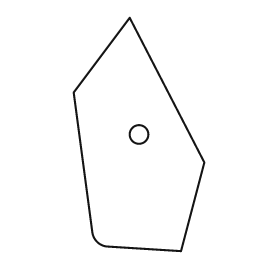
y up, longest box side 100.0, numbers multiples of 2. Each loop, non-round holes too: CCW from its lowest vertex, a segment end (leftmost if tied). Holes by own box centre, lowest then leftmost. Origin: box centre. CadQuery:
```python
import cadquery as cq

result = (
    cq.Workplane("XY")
    .moveTo(18.0, -50.0)
    .lineTo(28.0, -12.0)
    .lineTo(-4.0, 50.0)
    .lineTo(-28.0, 18.0)
    .lineTo(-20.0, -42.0)
    .threePointArc((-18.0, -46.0), (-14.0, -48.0))
    .close()
    .moveTo(0.0, 0.0)
    .circle(4.0)
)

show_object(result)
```